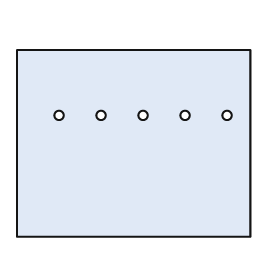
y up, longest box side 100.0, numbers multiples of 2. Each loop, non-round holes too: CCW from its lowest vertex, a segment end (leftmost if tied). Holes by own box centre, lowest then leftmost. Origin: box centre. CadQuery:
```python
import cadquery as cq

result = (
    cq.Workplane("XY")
    .moveTo(-50.0, -40.0)
    .lineTo(50.0, -40.0)
    .lineTo(50.0, 40.0)
    .lineTo(-50.0, 40.0)
    .close()
    .moveTo(-32.0, 12.0)
    .circle(2.0)
    .moveTo(-14.0, 12.0)
    .circle(2.0)
    .moveTo(4.0, 12.0)
    .circle(2.0)
    .moveTo(22.0, 12.0)
    .circle(2.0)
    .moveTo(40.0, 12.0)
    .circle(2.0)
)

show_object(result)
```